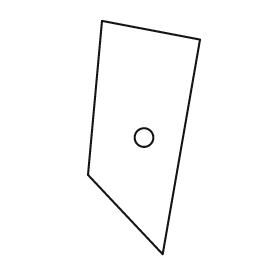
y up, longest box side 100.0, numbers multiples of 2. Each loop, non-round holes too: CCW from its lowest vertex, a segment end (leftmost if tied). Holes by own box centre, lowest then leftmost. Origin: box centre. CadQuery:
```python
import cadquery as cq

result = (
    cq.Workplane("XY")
    .moveTo(8.0, -50.0)
    .lineTo(24.0, 42.0)
    .lineTo(-18.0, 50.0)
    .lineTo(-24.0, -16.0)
    .close()
    .moveTo(0.0, 0.0)
    .circle(4.0)
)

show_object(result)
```